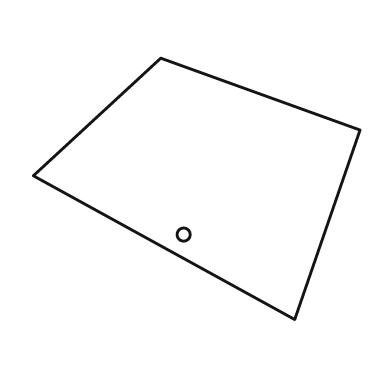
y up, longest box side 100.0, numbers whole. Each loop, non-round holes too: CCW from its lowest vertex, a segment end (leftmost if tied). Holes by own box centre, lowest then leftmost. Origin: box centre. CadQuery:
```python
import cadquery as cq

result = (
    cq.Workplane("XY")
    .moveTo(30.0, -40.0)
    .lineTo(50.0, 18.0)
    .lineTo(-11.0, 40.0)
    .lineTo(-50.0, 4.0)
    .close()
    .moveTo(-4.0, -14.0)
    .circle(2.0)
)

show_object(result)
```